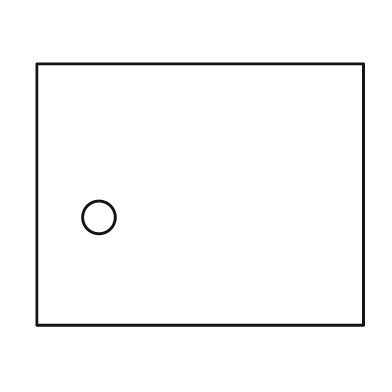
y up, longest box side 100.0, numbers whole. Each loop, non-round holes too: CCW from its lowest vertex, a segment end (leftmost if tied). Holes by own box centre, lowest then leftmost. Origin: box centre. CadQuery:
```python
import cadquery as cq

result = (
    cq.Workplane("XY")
    .moveTo(-50.0, -40.0)
    .lineTo(50.0, -40.0)
    .lineTo(50.0, 40.0)
    .lineTo(-50.0, 40.0)
    .close()
    .moveTo(-31.0, -7.0)
    .circle(5.0)
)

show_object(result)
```